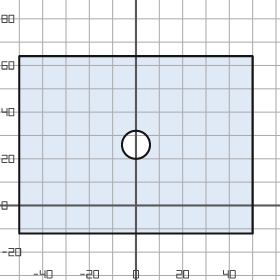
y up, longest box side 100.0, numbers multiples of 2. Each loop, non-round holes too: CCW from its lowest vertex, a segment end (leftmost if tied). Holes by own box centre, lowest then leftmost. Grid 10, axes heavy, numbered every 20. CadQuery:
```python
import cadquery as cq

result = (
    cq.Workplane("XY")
    .moveTo(-50.0, -12.0)
    .lineTo(50.0, -12.0)
    .lineTo(50.0, 64.0)
    .lineTo(-50.0, 64.0)
    .close()
    .moveTo(0.0, 26.0)
    .circle(6.0)
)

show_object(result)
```